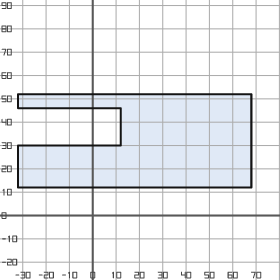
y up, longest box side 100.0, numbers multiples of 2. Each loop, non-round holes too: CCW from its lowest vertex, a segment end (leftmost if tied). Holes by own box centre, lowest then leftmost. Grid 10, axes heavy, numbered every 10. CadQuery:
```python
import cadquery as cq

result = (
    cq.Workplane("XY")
    .moveTo(-32.0, 12.0)
    .lineTo(68.0, 12.0)
    .lineTo(68.0, 52.0)
    .lineTo(-32.0, 52.0)
    .lineTo(-32.0, 46.0)
    .lineTo(12.0, 46.0)
    .lineTo(12.0, 30.0)
    .lineTo(-32.0, 30.0)
    .close()
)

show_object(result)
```